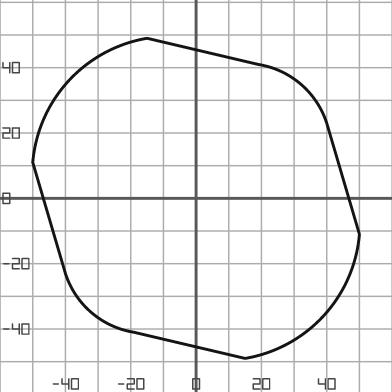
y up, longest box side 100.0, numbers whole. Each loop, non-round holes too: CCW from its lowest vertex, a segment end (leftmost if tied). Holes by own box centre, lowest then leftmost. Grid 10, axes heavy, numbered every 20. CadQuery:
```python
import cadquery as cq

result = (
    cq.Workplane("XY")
    .moveTo(15.0, -49.0)
    .threePointArc((39.0, -36.0), (50.0, -11.0))
    .lineTo(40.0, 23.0)
    .threePointArc((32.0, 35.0), (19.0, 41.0))
    .lineTo(-15.0, 49.0)
    .threePointArc((-39.0, 36.0), (-50.0, 11.0))
    .lineTo(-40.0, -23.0)
    .threePointArc((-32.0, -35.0), (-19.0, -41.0))
    .close()
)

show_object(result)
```